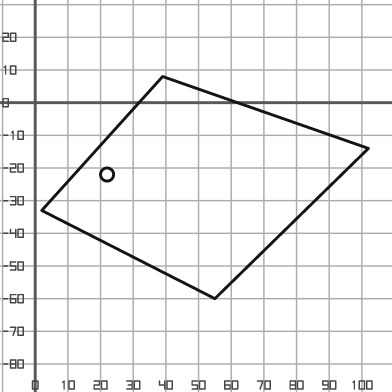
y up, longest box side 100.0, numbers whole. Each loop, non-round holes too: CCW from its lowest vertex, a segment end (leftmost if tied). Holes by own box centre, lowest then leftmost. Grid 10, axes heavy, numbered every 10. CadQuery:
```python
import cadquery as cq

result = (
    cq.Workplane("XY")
    .moveTo(55.0, -60.0)
    .lineTo(102.0, -14.0)
    .lineTo(39.0, 8.0)
    .lineTo(2.0, -33.0)
    .close()
    .moveTo(22.0, -22.0)
    .circle(2.0)
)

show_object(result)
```